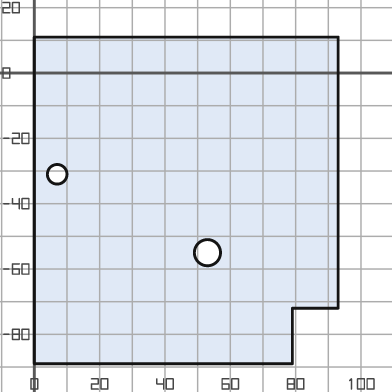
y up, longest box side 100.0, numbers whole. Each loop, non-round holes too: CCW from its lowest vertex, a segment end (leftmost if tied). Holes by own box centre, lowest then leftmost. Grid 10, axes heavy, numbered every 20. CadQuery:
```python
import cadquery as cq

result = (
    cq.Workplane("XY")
    .moveTo(0.0, -89.0)
    .lineTo(79.0, -89.0)
    .lineTo(79.0, -72.0)
    .lineTo(93.0, -72.0)
    .lineTo(93.0, 11.0)
    .lineTo(0.0, 11.0)
    .close()
    .moveTo(53.0, -55.0)
    .circle(4.0)
    .moveTo(7.0, -31.0)
    .circle(3.0)
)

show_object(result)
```